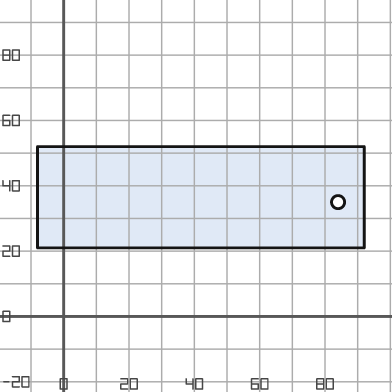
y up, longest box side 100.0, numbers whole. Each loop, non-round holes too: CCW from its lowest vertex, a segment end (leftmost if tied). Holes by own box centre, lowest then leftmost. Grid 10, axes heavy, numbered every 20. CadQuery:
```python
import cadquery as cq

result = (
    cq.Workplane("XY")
    .moveTo(-8.0, 21.0)
    .lineTo(92.0, 21.0)
    .lineTo(92.0, 52.0)
    .lineTo(-8.0, 52.0)
    .close()
    .moveTo(84.0, 35.0)
    .circle(2.0)
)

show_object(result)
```